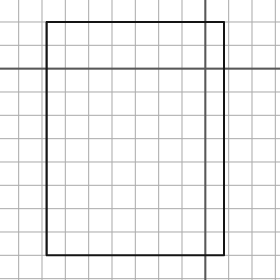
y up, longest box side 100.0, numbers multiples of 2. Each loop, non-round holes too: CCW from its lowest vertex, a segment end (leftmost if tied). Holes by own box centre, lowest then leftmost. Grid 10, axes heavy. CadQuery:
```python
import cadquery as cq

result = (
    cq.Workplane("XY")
    .moveTo(-68.0, -80.0)
    .lineTo(8.0, -80.0)
    .lineTo(8.0, 20.0)
    .lineTo(-68.0, 20.0)
    .close()
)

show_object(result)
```